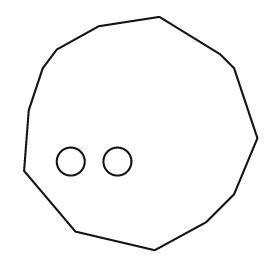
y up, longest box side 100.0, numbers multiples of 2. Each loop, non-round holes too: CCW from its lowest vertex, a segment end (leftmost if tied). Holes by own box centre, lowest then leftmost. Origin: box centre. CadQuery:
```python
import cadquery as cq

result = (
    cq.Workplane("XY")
    .moveTo(6.0, -50.0)
    .lineTo(28.0, -38.0)
    .lineTo(40.0, -26.0)
    .lineTo(50.0, -2.0)
    .lineTo(40.0, 28.0)
    .lineTo(34.0, 34.0)
    .lineTo(8.0, 50.0)
    .lineTo(-18.0, 46.0)
    .lineTo(-36.0, 36.0)
    .lineTo(-42.0, 28.0)
    .lineTo(-48.0, 10.0)
    .lineTo(-50.0, -16.0)
    .lineTo(-28.0, -42.0)
    .close()
    .moveTo(-30.0, -12.0)
    .circle(6.0)
    .moveTo(-10.0, -12.0)
    .circle(6.0)
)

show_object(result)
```